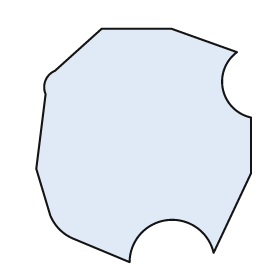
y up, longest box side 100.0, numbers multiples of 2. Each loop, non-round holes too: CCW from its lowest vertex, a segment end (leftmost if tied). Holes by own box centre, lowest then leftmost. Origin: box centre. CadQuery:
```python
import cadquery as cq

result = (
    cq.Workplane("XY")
    .moveTo(-6.0, -50.0)
    .threePointArc((10.0, -32.0), (30.0, -46.0))
    .lineTo(46.0, -12.0)
    .lineTo(46.0, 12.0)
    .threePointArc((34.0, 24.0), (40.0, 40.0))
    .lineTo(12.0, 50.0)
    .lineTo(-18.0, 50.0)
    .lineTo(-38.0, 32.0)
    .threePointArc((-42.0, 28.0), (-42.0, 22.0))
    .lineTo(-46.0, -10.0)
    .lineTo(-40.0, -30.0)
    .threePointArc((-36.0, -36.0), (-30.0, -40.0))
    .close()
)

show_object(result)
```